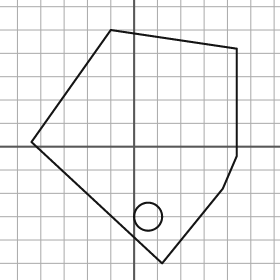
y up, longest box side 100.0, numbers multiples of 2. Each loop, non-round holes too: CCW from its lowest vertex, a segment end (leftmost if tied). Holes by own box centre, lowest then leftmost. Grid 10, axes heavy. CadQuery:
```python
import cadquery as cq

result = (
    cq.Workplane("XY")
    .moveTo(12.0, -50.0)
    .lineTo(38.0, -18.0)
    .lineTo(44.0, -4.0)
    .lineTo(44.0, 42.0)
    .lineTo(-10.0, 50.0)
    .lineTo(-44.0, 2.0)
    .close()
    .moveTo(6.0, -30.0)
    .circle(6.0)
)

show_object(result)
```